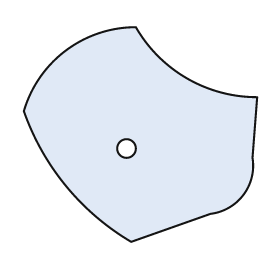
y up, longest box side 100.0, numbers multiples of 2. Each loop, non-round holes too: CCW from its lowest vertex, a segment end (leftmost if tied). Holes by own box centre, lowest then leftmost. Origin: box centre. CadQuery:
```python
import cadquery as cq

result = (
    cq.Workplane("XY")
    .moveTo(-4.0, -46.0)
    .lineTo(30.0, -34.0)
    .threePointArc((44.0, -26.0), (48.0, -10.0))
    .lineTo(50.0, 16.0)
    .threePointArc((20.0, 24.0), (-2.0, 46.0))
    .threePointArc((-32.0, 36.0), (-50.0, 10.0))
    .threePointArc((-32.0, -22.0), (-4.0, -46.0))
    .close()
    .moveTo(-6.0, -6.0)
    .circle(4.0)
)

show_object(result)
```